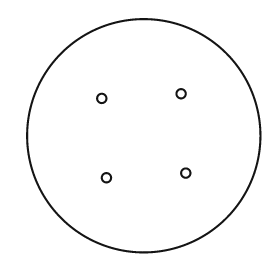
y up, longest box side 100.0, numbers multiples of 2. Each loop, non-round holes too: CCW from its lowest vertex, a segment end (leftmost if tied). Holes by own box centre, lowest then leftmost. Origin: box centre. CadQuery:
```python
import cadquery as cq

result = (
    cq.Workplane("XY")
    .moveTo(0.0, 0.0)
    .circle(50.0)
    .moveTo(-16.0, -18.0)
    .circle(2.0)
    .moveTo(18.0, -16.0)
    .circle(2.0)
    .moveTo(-18.0, 16.0)
    .circle(2.0)
    .moveTo(16.0, 18.0)
    .circle(2.0)
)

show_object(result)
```